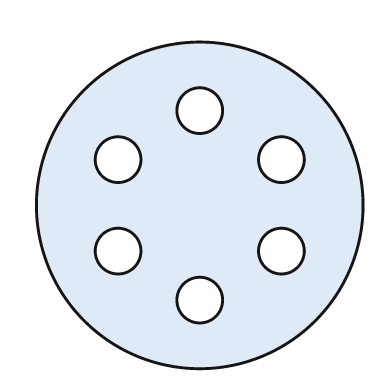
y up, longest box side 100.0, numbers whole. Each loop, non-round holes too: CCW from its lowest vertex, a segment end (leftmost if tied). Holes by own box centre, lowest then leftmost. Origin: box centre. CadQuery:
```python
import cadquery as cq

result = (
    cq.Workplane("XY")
    .moveTo(0.0, 0.0)
    .circle(50.0)
    .moveTo(0.0, -29.0)
    .circle(7.0)
    .moveTo(-25.0, -14.0)
    .circle(7.0)
    .moveTo(25.0, -14.0)
    .circle(7.0)
    .moveTo(-25.0, 14.0)
    .circle(7.0)
    .moveTo(25.0, 14.0)
    .circle(7.0)
    .moveTo(0.0, 29.0)
    .circle(7.0)
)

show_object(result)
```